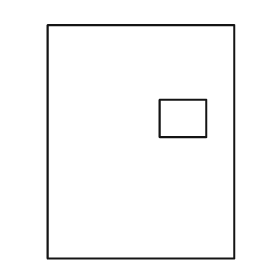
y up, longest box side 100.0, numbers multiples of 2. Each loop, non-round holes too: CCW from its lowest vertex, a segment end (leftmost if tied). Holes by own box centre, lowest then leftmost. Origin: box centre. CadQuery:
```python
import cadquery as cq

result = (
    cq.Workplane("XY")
    .moveTo(-40.0, -50.0)
    .lineTo(40.0, -50.0)
    .lineTo(40.0, 50.0)
    .lineTo(-40.0, 50.0)
    .close()
    .moveTo(8.0, 2.0)
    .lineTo(28.0, 2.0)
    .lineTo(28.0, 18.0)
    .lineTo(8.0, 18.0)
    .close()
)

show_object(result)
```